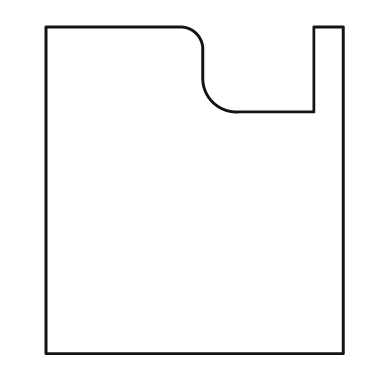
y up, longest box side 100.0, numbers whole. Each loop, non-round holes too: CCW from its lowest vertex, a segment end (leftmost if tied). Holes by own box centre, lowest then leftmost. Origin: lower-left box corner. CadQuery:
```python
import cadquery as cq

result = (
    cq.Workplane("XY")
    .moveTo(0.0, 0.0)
    .lineTo(91.0, 0.0)
    .lineTo(91.0, 100.0)
    .lineTo(82.0, 100.0)
    .lineTo(82.0, 74.0)
    .lineTo(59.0, 74.0)
    .threePointArc((51.0, 77.0), (48.0, 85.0))
    .lineTo(48.0, 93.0)
    .threePointArc((46.0, 98.0), (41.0, 100.0))
    .lineTo(0.0, 100.0)
    .close()
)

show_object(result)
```